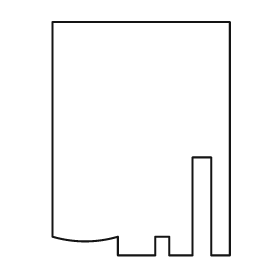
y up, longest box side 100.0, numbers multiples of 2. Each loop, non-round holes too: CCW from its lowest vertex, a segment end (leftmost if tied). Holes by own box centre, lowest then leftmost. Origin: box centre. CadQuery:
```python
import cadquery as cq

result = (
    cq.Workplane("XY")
    .moveTo(-10.0, -50.0)
    .lineTo(6.0, -50.0)
    .lineTo(6.0, -42.0)
    .lineTo(12.0, -42.0)
    .lineTo(12.0, -50.0)
    .lineTo(22.0, -50.0)
    .lineTo(22.0, -8.0)
    .lineTo(30.0, -8.0)
    .lineTo(30.0, -50.0)
    .lineTo(38.0, -50.0)
    .lineTo(38.0, 50.0)
    .lineTo(-38.0, 50.0)
    .lineTo(-38.0, -42.0)
    .threePointArc((-24.0, -44.0), (-10.0, -42.0))
    .close()
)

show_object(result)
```